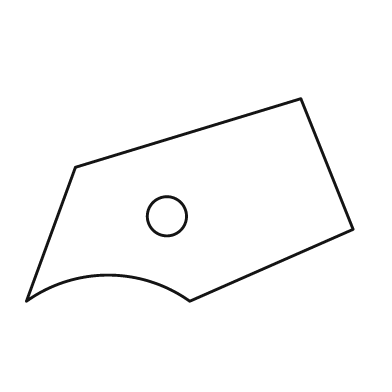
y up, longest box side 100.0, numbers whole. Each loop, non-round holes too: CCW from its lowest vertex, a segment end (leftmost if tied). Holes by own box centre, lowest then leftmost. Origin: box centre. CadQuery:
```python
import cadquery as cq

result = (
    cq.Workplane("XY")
    .moveTo(-50.0, -31.0)
    .threePointArc((-25.0, -23.0), (0.0, -31.0))
    .lineTo(50.0, -9.0)
    .lineTo(34.0, 31.0)
    .lineTo(-35.0, 10.0)
    .close()
    .moveTo(-7.0, -5.0)
    .circle(6.0)
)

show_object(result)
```